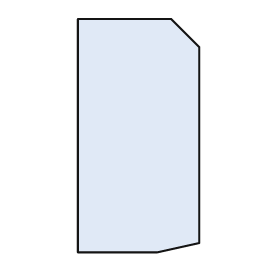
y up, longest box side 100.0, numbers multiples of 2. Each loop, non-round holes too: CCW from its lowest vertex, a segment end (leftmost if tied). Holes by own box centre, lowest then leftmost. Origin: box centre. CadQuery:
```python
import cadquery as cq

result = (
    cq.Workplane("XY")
    .moveTo(-26.0, -50.0)
    .lineTo(8.0, -50.0)
    .lineTo(26.0, -46.0)
    .lineTo(26.0, 38.0)
    .lineTo(14.0, 50.0)
    .lineTo(-26.0, 50.0)
    .close()
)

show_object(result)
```